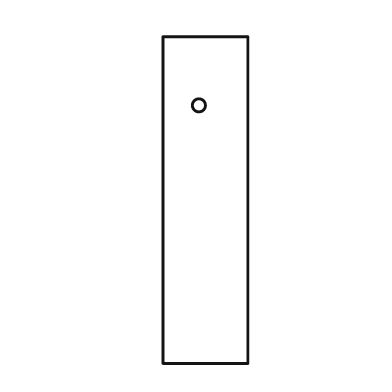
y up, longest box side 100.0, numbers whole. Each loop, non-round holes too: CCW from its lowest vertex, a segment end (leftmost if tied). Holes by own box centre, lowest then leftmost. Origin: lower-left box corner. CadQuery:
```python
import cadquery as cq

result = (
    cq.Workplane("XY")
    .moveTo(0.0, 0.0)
    .lineTo(26.0, 0.0)
    .lineTo(26.0, 100.0)
    .lineTo(0.0, 100.0)
    .close()
    .moveTo(11.0, 79.0)
    .circle(2.0)
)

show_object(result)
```